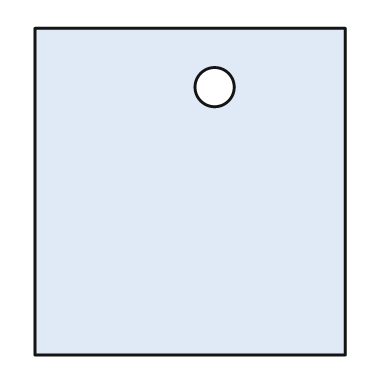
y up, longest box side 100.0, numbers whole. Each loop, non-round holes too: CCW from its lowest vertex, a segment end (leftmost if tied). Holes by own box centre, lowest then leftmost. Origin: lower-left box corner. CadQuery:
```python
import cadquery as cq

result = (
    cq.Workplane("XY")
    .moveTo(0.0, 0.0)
    .lineTo(95.0, 0.0)
    .lineTo(95.0, 100.0)
    .lineTo(0.0, 100.0)
    .close()
    .moveTo(55.0, 82.0)
    .circle(6.0)
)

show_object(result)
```